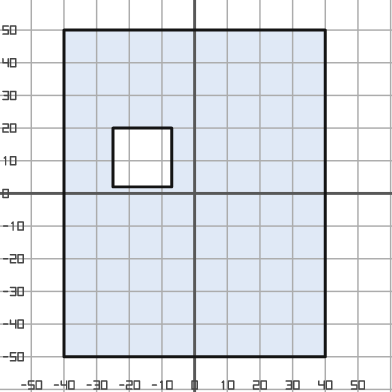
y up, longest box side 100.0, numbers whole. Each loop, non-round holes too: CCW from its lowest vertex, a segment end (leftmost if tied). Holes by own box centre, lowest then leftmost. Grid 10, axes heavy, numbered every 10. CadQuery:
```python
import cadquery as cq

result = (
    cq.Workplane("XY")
    .moveTo(-40.0, -50.0)
    .lineTo(40.0, -50.0)
    .lineTo(40.0, 50.0)
    .lineTo(-40.0, 50.0)
    .close()
    .moveTo(-25.0, 2.0)
    .lineTo(-7.0, 2.0)
    .lineTo(-7.0, 20.0)
    .lineTo(-25.0, 20.0)
    .close()
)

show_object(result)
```